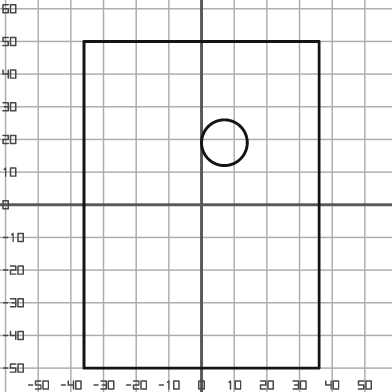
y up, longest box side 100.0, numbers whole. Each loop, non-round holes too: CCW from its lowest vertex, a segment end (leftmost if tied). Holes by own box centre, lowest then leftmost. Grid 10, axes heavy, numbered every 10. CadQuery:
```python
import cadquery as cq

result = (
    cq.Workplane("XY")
    .moveTo(-36.0, -50.0)
    .lineTo(36.0, -50.0)
    .lineTo(36.0, 50.0)
    .lineTo(-36.0, 50.0)
    .close()
    .moveTo(7.0, 19.0)
    .circle(7.0)
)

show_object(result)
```